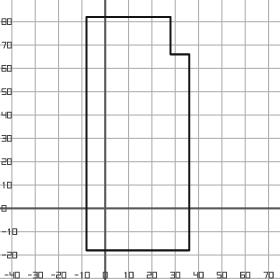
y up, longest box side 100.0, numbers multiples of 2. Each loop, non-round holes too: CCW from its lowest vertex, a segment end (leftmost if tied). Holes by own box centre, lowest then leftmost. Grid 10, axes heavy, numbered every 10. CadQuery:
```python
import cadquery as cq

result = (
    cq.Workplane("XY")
    .moveTo(-8.0, -18.0)
    .lineTo(36.0, -18.0)
    .lineTo(36.0, 66.0)
    .lineTo(28.0, 66.0)
    .lineTo(28.0, 82.0)
    .lineTo(-8.0, 82.0)
    .close()
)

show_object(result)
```